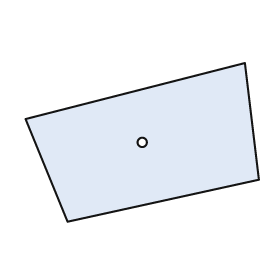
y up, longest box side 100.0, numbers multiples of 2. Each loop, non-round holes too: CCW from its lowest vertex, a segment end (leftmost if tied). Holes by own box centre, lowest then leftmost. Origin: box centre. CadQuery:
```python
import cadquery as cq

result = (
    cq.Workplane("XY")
    .moveTo(-32.0, -34.0)
    .lineTo(50.0, -16.0)
    .lineTo(44.0, 34.0)
    .lineTo(-50.0, 10.0)
    .close()
    .moveTo(0.0, 0.0)
    .circle(2.0)
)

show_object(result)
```